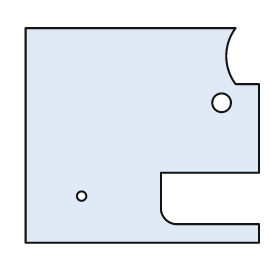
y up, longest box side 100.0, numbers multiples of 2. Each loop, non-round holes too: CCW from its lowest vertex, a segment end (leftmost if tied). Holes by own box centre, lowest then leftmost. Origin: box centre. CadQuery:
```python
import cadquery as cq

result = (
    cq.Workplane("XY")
    .moveTo(-50.0, -46.0)
    .lineTo(50.0, -46.0)
    .lineTo(50.0, -38.0)
    .lineTo(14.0, -38.0)
    .threePointArc((10.0, -36.0), (8.0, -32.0))
    .lineTo(8.0, -16.0)
    .lineTo(50.0, -16.0)
    .lineTo(50.0, 22.0)
    .lineTo(40.0, 22.0)
    .threePointArc((36.0, 34.0), (40.0, 46.0))
    .lineTo(-50.0, 46.0)
    .close()
    .moveTo(-26.0, -26.0)
    .circle(2.0)
    .moveTo(34.0, 14.0)
    .circle(4.0)
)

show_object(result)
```